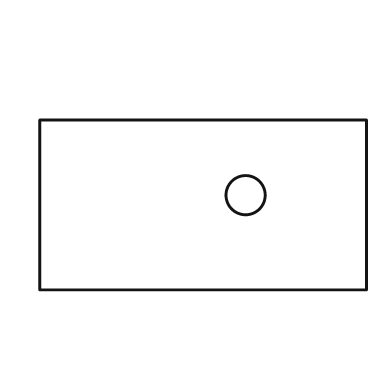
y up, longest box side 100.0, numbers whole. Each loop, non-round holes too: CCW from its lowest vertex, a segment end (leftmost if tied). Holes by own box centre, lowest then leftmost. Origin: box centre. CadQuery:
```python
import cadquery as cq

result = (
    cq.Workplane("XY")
    .moveTo(-50.0, -26.0)
    .lineTo(50.0, -26.0)
    .lineTo(50.0, 26.0)
    .lineTo(-50.0, 26.0)
    .close()
    .moveTo(13.0, 3.0)
    .circle(6.0)
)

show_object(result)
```